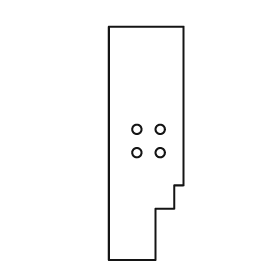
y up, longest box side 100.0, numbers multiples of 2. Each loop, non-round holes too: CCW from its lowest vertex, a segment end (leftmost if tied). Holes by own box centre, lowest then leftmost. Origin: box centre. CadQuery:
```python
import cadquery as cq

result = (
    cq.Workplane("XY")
    .moveTo(-16.0, -50.0)
    .lineTo(4.0, -50.0)
    .lineTo(4.0, -28.0)
    .lineTo(12.0, -28.0)
    .lineTo(12.0, -18.0)
    .lineTo(16.0, -18.0)
    .lineTo(16.0, 50.0)
    .lineTo(-16.0, 50.0)
    .close()
    .moveTo(-4.0, -4.0)
    .circle(2.0)
    .moveTo(6.0, -4.0)
    .circle(2.0)
    .moveTo(-4.0, 6.0)
    .circle(2.0)
    .moveTo(6.0, 6.0)
    .circle(2.0)
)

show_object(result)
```